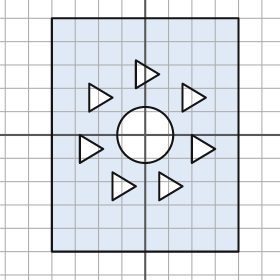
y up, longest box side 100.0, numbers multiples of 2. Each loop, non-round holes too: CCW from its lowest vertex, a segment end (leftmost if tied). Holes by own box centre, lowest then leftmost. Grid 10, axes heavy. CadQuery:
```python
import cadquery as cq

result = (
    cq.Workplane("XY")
    .moveTo(-40.0, -50.0)
    .lineTo(40.0, -50.0)
    .lineTo(40.0, 50.0)
    .lineTo(-40.0, 50.0)
    .close()
    .moveTo(-14.0, -28.0)
    .lineTo(-4.0, -22.0)
    .lineTo(-14.0, -16.0)
    .close()
    .moveTo(6.0, -28.0)
    .lineTo(16.0, -22.0)
    .lineTo(6.0, -16.0)
    .close()
    .moveTo(-28.0, -12.0)
    .lineTo(-18.0, -6.0)
    .lineTo(-28.0, 0.0)
    .close()
    .moveTo(20.0, -12.0)
    .lineTo(30.0, -6.0)
    .lineTo(20.0, 0.0)
    .close()
    .moveTo(0.0, 0.0)
    .circle(12.0)
    .moveTo(-24.0, 10.0)
    .lineTo(-14.0, 16.0)
    .lineTo(-24.0, 22.0)
    .close()
    .moveTo(16.0, 10.0)
    .lineTo(26.0, 16.0)
    .lineTo(16.0, 22.0)
    .close()
    .moveTo(-4.0, 20.0)
    .lineTo(6.0, 26.0)
    .lineTo(-4.0, 32.0)
    .close()
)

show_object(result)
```